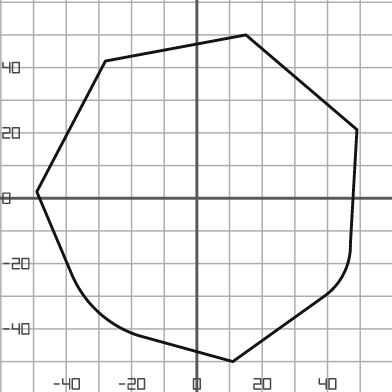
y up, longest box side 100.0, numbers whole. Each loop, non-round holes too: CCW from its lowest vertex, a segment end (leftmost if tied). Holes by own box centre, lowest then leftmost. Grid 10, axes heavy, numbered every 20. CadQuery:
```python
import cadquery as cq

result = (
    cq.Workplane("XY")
    .moveTo(11.0, -50.0)
    .lineTo(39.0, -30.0)
    .threePointArc((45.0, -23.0), (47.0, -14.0))
    .lineTo(49.0, 21.0)
    .lineTo(15.0, 50.0)
    .lineTo(-28.0, 42.0)
    .lineTo(-49.0, 2.0)
    .lineTo(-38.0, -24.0)
    .threePointArc((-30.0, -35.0), (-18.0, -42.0))
    .close()
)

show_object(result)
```